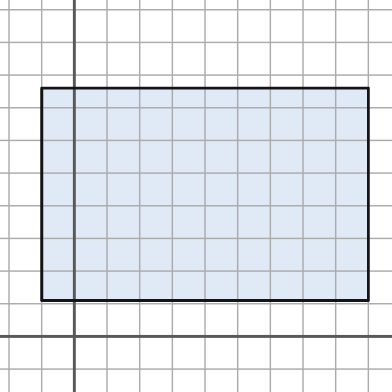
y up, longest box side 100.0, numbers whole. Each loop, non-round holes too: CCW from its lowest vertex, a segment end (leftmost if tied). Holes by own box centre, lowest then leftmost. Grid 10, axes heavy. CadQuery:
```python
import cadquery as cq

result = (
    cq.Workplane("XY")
    .moveTo(-10.0, 11.0)
    .lineTo(90.0, 11.0)
    .lineTo(90.0, 76.0)
    .lineTo(-10.0, 76.0)
    .close()
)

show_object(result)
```